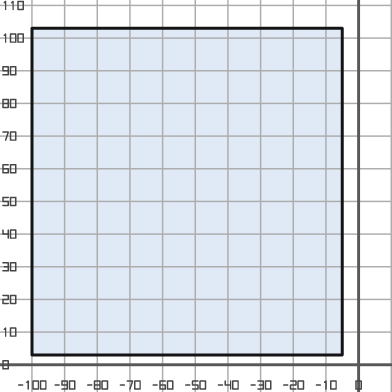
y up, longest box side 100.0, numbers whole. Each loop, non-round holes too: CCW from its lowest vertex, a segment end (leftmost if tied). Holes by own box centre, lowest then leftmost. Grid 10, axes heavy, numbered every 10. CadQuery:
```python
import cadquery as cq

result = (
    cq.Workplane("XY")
    .moveTo(-100.0, 3.0)
    .lineTo(-5.0, 3.0)
    .lineTo(-5.0, 103.0)
    .lineTo(-100.0, 103.0)
    .close()
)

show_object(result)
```